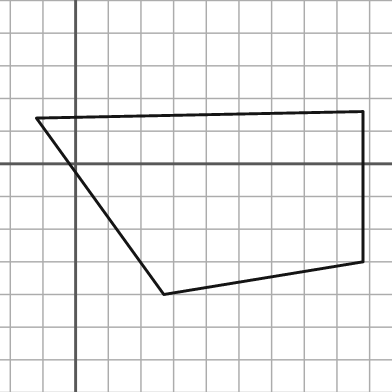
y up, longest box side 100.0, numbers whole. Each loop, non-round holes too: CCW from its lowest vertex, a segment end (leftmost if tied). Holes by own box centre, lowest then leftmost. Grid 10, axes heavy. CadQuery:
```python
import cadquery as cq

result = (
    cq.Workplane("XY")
    .moveTo(27.0, -40.0)
    .lineTo(88.0, -30.0)
    .lineTo(88.0, 16.0)
    .lineTo(-12.0, 14.0)
    .close()
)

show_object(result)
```